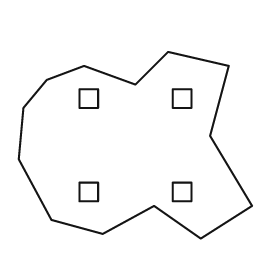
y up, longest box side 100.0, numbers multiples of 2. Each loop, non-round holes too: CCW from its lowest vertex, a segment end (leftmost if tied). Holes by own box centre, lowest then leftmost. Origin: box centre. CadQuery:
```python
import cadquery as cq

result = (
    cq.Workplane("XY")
    .moveTo(28.0, -40.0)
    .lineTo(50.0, -26.0)
    .lineTo(32.0, 4.0)
    .lineTo(40.0, 34.0)
    .lineTo(14.0, 40.0)
    .lineTo(0.0, 26.0)
    .lineTo(-22.0, 34.0)
    .lineTo(-38.0, 28.0)
    .lineTo(-48.0, 16.0)
    .lineTo(-50.0, -6.0)
    .lineTo(-36.0, -32.0)
    .lineTo(-14.0, -38.0)
    .lineTo(8.0, -26.0)
    .close()
    .moveTo(-24.0, -24.0)
    .lineTo(-16.0, -24.0)
    .lineTo(-16.0, -16.0)
    .lineTo(-24.0, -16.0)
    .close()
    .moveTo(16.0, -24.0)
    .lineTo(24.0, -24.0)
    .lineTo(24.0, -16.0)
    .lineTo(16.0, -16.0)
    .close()
    .moveTo(-24.0, 16.0)
    .lineTo(-16.0, 16.0)
    .lineTo(-16.0, 24.0)
    .lineTo(-24.0, 24.0)
    .close()
    .moveTo(16.0, 16.0)
    .lineTo(24.0, 16.0)
    .lineTo(24.0, 24.0)
    .lineTo(16.0, 24.0)
    .close()
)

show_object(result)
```